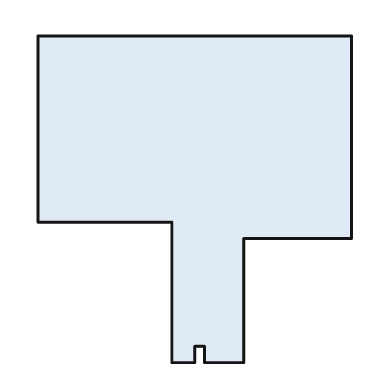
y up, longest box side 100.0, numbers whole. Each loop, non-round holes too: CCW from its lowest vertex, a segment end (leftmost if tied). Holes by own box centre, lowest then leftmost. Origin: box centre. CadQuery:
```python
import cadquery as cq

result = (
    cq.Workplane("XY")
    .moveTo(-7.0, -50.0)
    .lineTo(0.0, -50.0)
    .lineTo(0.0, -45.0)
    .lineTo(3.0, -45.0)
    .lineTo(3.0, -50.0)
    .lineTo(15.0, -50.0)
    .lineTo(15.0, -12.0)
    .lineTo(48.0, -12.0)
    .lineTo(48.0, 50.0)
    .lineTo(-48.0, 50.0)
    .lineTo(-48.0, -7.0)
    .lineTo(-7.0, -7.0)
    .close()
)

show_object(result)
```